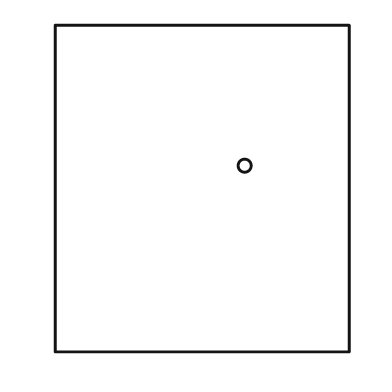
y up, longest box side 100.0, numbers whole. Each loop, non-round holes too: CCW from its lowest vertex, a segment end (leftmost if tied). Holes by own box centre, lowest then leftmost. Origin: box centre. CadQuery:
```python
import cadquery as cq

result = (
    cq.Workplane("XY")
    .moveTo(-45.0, -50.0)
    .lineTo(45.0, -50.0)
    .lineTo(45.0, 50.0)
    .lineTo(-45.0, 50.0)
    .close()
    .moveTo(13.0, 7.0)
    .circle(2.0)
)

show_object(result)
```